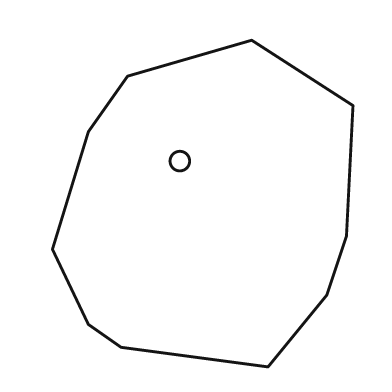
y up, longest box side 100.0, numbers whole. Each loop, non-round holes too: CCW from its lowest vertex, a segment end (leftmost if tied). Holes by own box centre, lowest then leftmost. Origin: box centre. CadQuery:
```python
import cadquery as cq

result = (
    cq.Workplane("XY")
    .moveTo(20.0, -50.0)
    .lineTo(38.0, -28.0)
    .lineTo(44.0, -10.0)
    .lineTo(46.0, 30.0)
    .lineTo(15.0, 50.0)
    .lineTo(-23.0, 39.0)
    .lineTo(-35.0, 22.0)
    .lineTo(-46.0, -14.0)
    .lineTo(-35.0, -37.0)
    .lineTo(-25.0, -44.0)
    .close()
    .moveTo(-7.0, 13.0)
    .circle(3.0)
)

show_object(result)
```